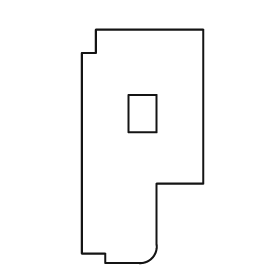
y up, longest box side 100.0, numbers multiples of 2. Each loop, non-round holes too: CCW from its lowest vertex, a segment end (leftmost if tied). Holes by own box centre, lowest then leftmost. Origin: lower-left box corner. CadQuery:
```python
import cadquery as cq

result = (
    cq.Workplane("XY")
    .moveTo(10.0, 0.0)
    .lineTo(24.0, 0.0)
    .threePointArc((30.0, 2.0), (32.0, 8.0))
    .lineTo(32.0, 34.0)
    .lineTo(52.0, 34.0)
    .lineTo(52.0, 100.0)
    .lineTo(6.0, 100.0)
    .lineTo(6.0, 90.0)
    .lineTo(0.0, 90.0)
    .lineTo(0.0, 4.0)
    .lineTo(10.0, 4.0)
    .close()
    .moveTo(20.0, 56.0)
    .lineTo(32.0, 56.0)
    .lineTo(32.0, 72.0)
    .lineTo(20.0, 72.0)
    .close()
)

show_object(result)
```